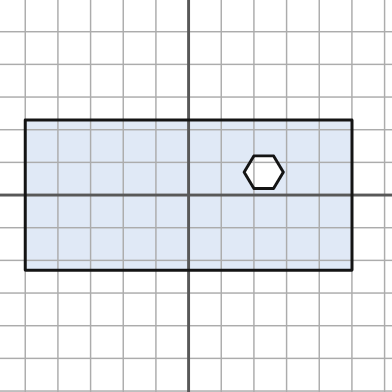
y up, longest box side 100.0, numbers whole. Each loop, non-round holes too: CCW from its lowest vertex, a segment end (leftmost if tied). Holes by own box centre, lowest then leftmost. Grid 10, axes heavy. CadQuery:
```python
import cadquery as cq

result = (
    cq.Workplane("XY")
    .moveTo(-50.0, -23.0)
    .lineTo(50.0, -23.0)
    .lineTo(50.0, 23.0)
    .lineTo(-50.0, 23.0)
    .close()
    .moveTo(20.0, 2.0)
    .lineTo(26.0, 2.0)
    .lineTo(29.0, 7.0)
    .lineTo(26.0, 12.0)
    .lineTo(20.0, 12.0)
    .lineTo(17.0, 7.0)
    .close()
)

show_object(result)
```